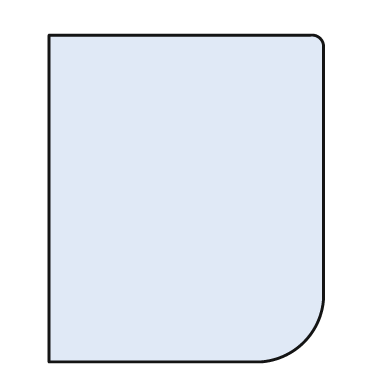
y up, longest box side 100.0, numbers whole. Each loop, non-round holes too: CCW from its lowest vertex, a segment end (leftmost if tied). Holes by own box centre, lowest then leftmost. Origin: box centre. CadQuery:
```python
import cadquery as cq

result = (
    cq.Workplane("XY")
    .moveTo(-42.0, -50.0)
    .lineTo(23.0, -50.0)
    .threePointArc((36.0, -44.0), (42.0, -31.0))
    .lineTo(42.0, 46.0)
    .threePointArc((41.0, 49.0), (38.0, 50.0))
    .lineTo(-42.0, 50.0)
    .close()
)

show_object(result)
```